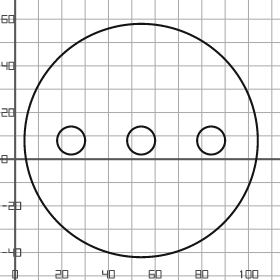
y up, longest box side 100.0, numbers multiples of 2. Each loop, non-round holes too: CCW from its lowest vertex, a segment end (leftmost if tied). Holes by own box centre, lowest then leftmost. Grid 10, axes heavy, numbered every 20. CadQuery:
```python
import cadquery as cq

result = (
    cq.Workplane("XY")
    .moveTo(54.0, 8.0)
    .circle(50.0)
    .moveTo(24.0, 8.0)
    .circle(6.0)
    .moveTo(54.0, 8.0)
    .circle(6.0)
    .moveTo(84.0, 8.0)
    .circle(6.0)
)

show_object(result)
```